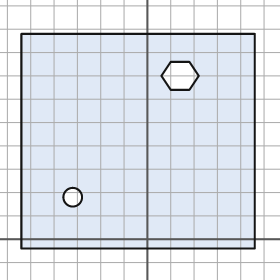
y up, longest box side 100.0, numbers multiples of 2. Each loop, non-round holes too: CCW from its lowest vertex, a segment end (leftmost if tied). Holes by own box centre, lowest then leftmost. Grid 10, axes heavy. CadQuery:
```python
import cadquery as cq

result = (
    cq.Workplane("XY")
    .moveTo(-54.0, -4.0)
    .lineTo(46.0, -4.0)
    .lineTo(46.0, 88.0)
    .lineTo(-54.0, 88.0)
    .close()
    .moveTo(-32.0, 18.0)
    .circle(4.0)
    .moveTo(10.0, 64.0)
    .lineTo(18.0, 64.0)
    .lineTo(22.0, 70.0)
    .lineTo(18.0, 76.0)
    .lineTo(10.0, 76.0)
    .lineTo(6.0, 70.0)
    .close()
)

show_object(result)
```